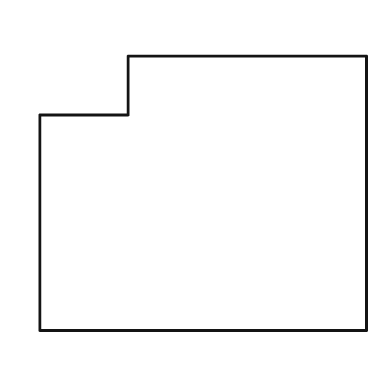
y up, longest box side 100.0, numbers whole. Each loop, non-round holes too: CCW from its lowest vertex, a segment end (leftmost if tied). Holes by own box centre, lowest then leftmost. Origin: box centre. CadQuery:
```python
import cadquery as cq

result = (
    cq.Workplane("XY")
    .moveTo(-50.0, -42.0)
    .lineTo(50.0, -42.0)
    .lineTo(50.0, 42.0)
    .lineTo(-23.0, 42.0)
    .lineTo(-23.0, 24.0)
    .lineTo(-50.0, 24.0)
    .close()
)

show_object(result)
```